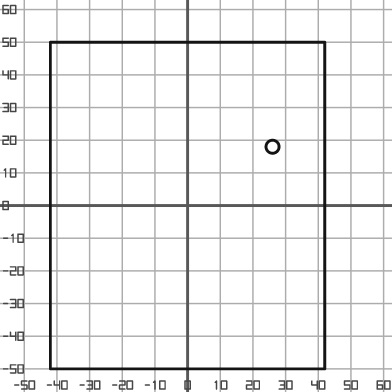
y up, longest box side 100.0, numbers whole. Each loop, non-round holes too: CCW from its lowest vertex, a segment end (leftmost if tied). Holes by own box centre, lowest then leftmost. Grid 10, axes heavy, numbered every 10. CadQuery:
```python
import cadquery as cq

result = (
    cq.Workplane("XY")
    .moveTo(-42.0, -50.0)
    .lineTo(42.0, -50.0)
    .lineTo(42.0, 50.0)
    .lineTo(-42.0, 50.0)
    .close()
    .moveTo(26.0, 18.0)
    .circle(2.0)
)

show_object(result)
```